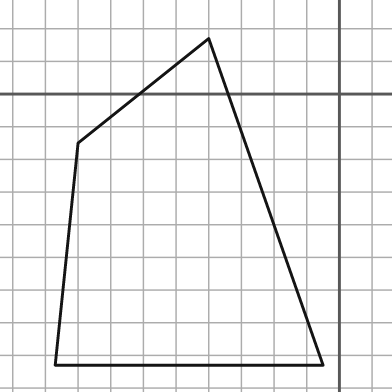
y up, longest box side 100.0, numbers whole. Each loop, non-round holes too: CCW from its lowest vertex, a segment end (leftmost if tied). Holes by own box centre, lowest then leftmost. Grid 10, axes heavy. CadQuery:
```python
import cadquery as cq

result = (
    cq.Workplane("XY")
    .moveTo(-87.0, -83.0)
    .lineTo(-5.0, -83.0)
    .lineTo(-40.0, 17.0)
    .lineTo(-80.0, -15.0)
    .close()
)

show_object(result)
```